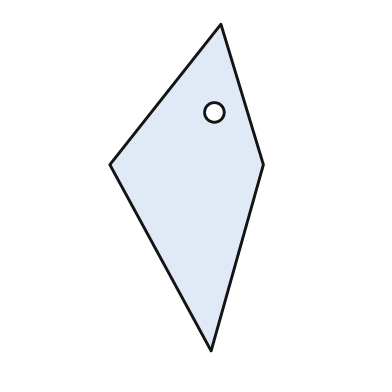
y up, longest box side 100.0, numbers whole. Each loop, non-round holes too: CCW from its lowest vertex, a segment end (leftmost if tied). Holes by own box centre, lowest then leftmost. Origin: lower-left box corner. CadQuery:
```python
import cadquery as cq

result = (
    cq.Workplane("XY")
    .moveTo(31.0, 0.0)
    .lineTo(47.0, 57.0)
    .lineTo(34.0, 100.0)
    .lineTo(0.0, 57.0)
    .close()
    .moveTo(32.0, 73.0)
    .circle(3.0)
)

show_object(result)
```